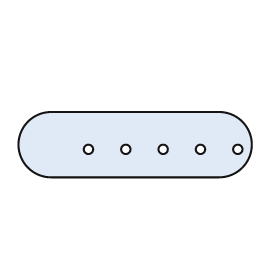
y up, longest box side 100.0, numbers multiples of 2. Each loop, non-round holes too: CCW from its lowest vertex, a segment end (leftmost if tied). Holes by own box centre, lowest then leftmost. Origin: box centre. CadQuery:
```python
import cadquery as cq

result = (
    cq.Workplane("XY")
    .moveTo(-36.0, -14.0)
    .lineTo(36.0, -14.0)
    .threePointArc((50.0, 0.0), (36.0, 14.0))
    .lineTo(-36.0, 14.0)
    .threePointArc((-50.0, 0.0), (-36.0, -14.0))
    .close()
    .moveTo(-20.0, -2.0)
    .circle(2.0)
    .moveTo(-4.0, -2.0)
    .circle(2.0)
    .moveTo(12.0, -2.0)
    .circle(2.0)
    .moveTo(28.0, -2.0)
    .circle(2.0)
    .moveTo(44.0, -2.0)
    .circle(2.0)
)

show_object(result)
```